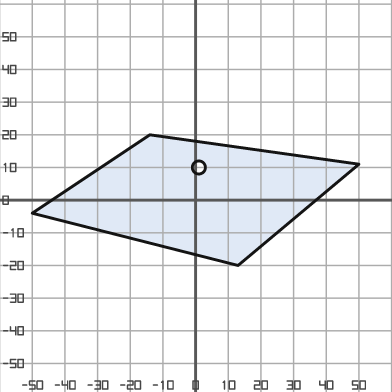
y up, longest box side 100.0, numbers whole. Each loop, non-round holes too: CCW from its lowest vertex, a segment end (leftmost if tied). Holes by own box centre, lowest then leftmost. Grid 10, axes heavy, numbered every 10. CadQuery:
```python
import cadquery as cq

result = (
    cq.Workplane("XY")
    .moveTo(13.0, -20.0)
    .lineTo(50.0, 11.0)
    .lineTo(-14.0, 20.0)
    .lineTo(-50.0, -4.0)
    .close()
    .moveTo(1.0, 10.0)
    .circle(2.0)
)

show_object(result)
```